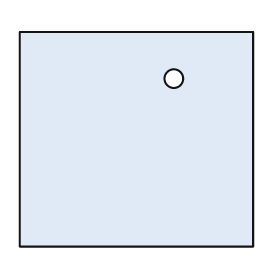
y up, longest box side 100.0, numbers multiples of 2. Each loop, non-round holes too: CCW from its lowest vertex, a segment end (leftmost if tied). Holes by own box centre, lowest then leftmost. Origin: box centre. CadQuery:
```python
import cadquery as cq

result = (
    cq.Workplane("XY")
    .moveTo(-50.0, -46.0)
    .lineTo(50.0, -46.0)
    .lineTo(50.0, 46.0)
    .lineTo(-50.0, 46.0)
    .close()
    .moveTo(16.0, 26.0)
    .circle(4.0)
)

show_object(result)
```